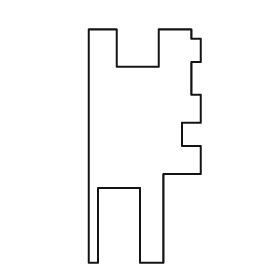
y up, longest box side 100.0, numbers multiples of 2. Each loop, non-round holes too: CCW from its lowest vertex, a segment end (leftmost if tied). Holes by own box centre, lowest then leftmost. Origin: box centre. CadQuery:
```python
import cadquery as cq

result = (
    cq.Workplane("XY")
    .moveTo(-24.0, -50.0)
    .lineTo(-20.0, -50.0)
    .lineTo(-20.0, -18.0)
    .lineTo(-2.0, -18.0)
    .lineTo(-2.0, -50.0)
    .lineTo(8.0, -50.0)
    .lineTo(8.0, -12.0)
    .lineTo(24.0, -12.0)
    .lineTo(24.0, 0.0)
    .lineTo(16.0, 0.0)
    .lineTo(16.0, 10.0)
    .lineTo(24.0, 10.0)
    .lineTo(24.0, 22.0)
    .lineTo(20.0, 22.0)
    .lineTo(20.0, 36.0)
    .lineTo(24.0, 36.0)
    .lineTo(24.0, 46.0)
    .lineTo(20.0, 46.0)
    .lineTo(20.0, 50.0)
    .lineTo(6.0, 50.0)
    .lineTo(6.0, 34.0)
    .lineTo(-12.0, 34.0)
    .lineTo(-12.0, 50.0)
    .lineTo(-24.0, 50.0)
    .close()
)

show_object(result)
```